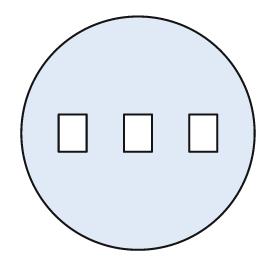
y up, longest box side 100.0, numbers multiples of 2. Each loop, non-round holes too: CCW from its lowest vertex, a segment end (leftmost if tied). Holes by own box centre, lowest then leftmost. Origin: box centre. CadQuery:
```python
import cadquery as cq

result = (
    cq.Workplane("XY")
    .moveTo(0.0, 0.0)
    .circle(50.0)
    .moveTo(-34.0, -8.0)
    .lineTo(-22.0, -8.0)
    .lineTo(-22.0, 8.0)
    .lineTo(-34.0, 8.0)
    .close()
    .moveTo(-6.0, -8.0)
    .lineTo(6.0, -8.0)
    .lineTo(6.0, 8.0)
    .lineTo(-6.0, 8.0)
    .close()
    .moveTo(22.0, -8.0)
    .lineTo(34.0, -8.0)
    .lineTo(34.0, 8.0)
    .lineTo(22.0, 8.0)
    .close()
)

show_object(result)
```